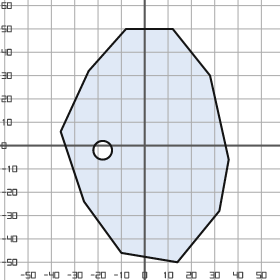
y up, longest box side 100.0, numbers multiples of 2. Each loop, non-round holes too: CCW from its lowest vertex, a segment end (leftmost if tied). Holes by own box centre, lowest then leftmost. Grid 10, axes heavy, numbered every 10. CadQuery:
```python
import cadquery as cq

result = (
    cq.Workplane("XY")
    .moveTo(14.0, -50.0)
    .lineTo(32.0, -28.0)
    .lineTo(36.0, -6.0)
    .lineTo(28.0, 30.0)
    .lineTo(12.0, 50.0)
    .lineTo(-8.0, 50.0)
    .lineTo(-24.0, 32.0)
    .lineTo(-36.0, 6.0)
    .lineTo(-26.0, -24.0)
    .lineTo(-10.0, -46.0)
    .close()
    .moveTo(-18.0, -2.0)
    .circle(4.0)
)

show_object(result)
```